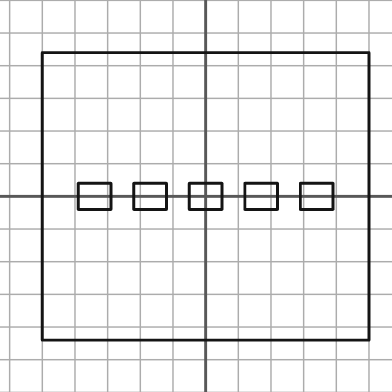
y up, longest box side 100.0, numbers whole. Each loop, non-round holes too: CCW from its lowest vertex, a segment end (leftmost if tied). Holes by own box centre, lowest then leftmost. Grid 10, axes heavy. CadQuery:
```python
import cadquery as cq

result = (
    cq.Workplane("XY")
    .moveTo(-50.0, -44.0)
    .lineTo(50.0, -44.0)
    .lineTo(50.0, 44.0)
    .lineTo(-50.0, 44.0)
    .close()
    .moveTo(-39.0, -4.0)
    .lineTo(-29.0, -4.0)
    .lineTo(-29.0, 4.0)
    .lineTo(-39.0, 4.0)
    .close()
    .moveTo(-22.0, -4.0)
    .lineTo(-12.0, -4.0)
    .lineTo(-12.0, 4.0)
    .lineTo(-22.0, 4.0)
    .close()
    .moveTo(-5.0, -4.0)
    .lineTo(5.0, -4.0)
    .lineTo(5.0, 4.0)
    .lineTo(-5.0, 4.0)
    .close()
    .moveTo(12.0, -4.0)
    .lineTo(22.0, -4.0)
    .lineTo(22.0, 4.0)
    .lineTo(12.0, 4.0)
    .close()
    .moveTo(29.0, -4.0)
    .lineTo(39.0, -4.0)
    .lineTo(39.0, 4.0)
    .lineTo(29.0, 4.0)
    .close()
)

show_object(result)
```